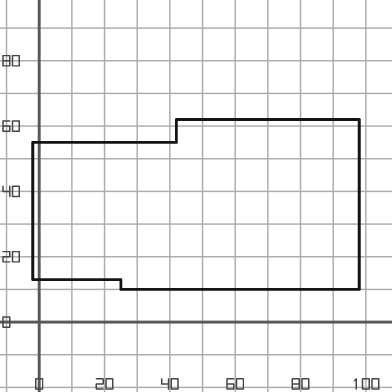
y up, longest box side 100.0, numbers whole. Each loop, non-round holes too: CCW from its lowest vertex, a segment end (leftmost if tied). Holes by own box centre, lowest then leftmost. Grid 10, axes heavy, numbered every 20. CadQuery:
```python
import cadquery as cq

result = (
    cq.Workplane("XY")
    .moveTo(25.0, 10.0)
    .lineTo(98.0, 10.0)
    .lineTo(98.0, 62.0)
    .lineTo(42.0, 62.0)
    .lineTo(42.0, 55.0)
    .lineTo(-2.0, 55.0)
    .lineTo(-2.0, 13.0)
    .lineTo(25.0, 13.0)
    .close()
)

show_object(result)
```